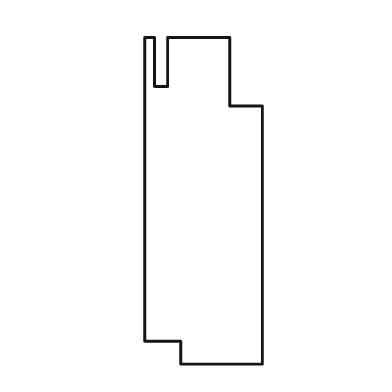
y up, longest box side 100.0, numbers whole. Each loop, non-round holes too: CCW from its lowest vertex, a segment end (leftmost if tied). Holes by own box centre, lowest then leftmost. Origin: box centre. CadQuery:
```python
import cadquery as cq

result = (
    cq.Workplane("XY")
    .moveTo(-7.0, -50.0)
    .lineTo(18.0, -50.0)
    .lineTo(18.0, 29.0)
    .lineTo(8.0, 29.0)
    .lineTo(8.0, 50.0)
    .lineTo(-11.0, 50.0)
    .lineTo(-11.0, 35.0)
    .lineTo(-15.0, 35.0)
    .lineTo(-15.0, 50.0)
    .lineTo(-18.0, 50.0)
    .lineTo(-18.0, -43.0)
    .lineTo(-7.0, -43.0)
    .close()
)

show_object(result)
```